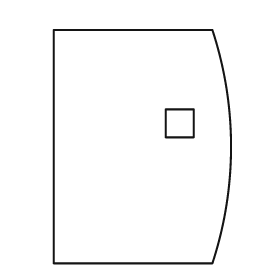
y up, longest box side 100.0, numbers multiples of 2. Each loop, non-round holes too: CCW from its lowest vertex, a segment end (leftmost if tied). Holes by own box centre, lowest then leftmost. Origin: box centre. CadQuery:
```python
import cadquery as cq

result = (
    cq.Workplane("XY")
    .moveTo(-38.0, -50.0)
    .lineTo(30.0, -50.0)
    .threePointArc((38.0, 0.0), (30.0, 50.0))
    .lineTo(-38.0, 50.0)
    .close()
    .moveTo(10.0, 4.0)
    .lineTo(22.0, 4.0)
    .lineTo(22.0, 16.0)
    .lineTo(10.0, 16.0)
    .close()
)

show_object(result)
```